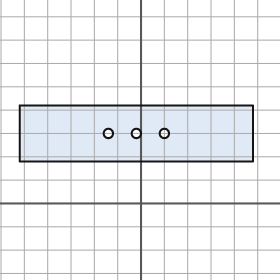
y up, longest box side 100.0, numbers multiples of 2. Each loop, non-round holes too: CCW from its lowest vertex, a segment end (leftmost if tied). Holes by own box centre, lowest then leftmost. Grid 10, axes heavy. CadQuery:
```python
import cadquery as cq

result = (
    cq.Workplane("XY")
    .moveTo(-52.0, 18.0)
    .lineTo(48.0, 18.0)
    .lineTo(48.0, 42.0)
    .lineTo(-52.0, 42.0)
    .close()
    .moveTo(-14.0, 30.0)
    .circle(2.0)
    .moveTo(-2.0, 30.0)
    .circle(2.0)
    .moveTo(10.0, 30.0)
    .circle(2.0)
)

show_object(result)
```